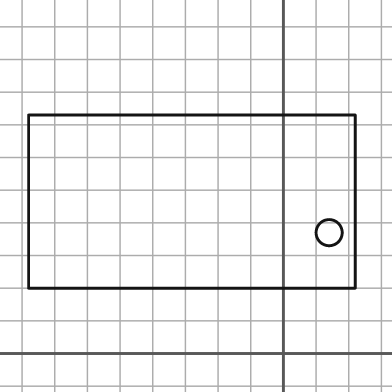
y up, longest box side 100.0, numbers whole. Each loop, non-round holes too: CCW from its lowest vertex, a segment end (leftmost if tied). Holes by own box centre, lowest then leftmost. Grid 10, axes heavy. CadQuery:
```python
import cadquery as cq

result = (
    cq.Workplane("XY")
    .moveTo(-78.0, 20.0)
    .lineTo(22.0, 20.0)
    .lineTo(22.0, 73.0)
    .lineTo(-78.0, 73.0)
    .close()
    .moveTo(14.0, 37.0)
    .circle(4.0)
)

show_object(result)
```